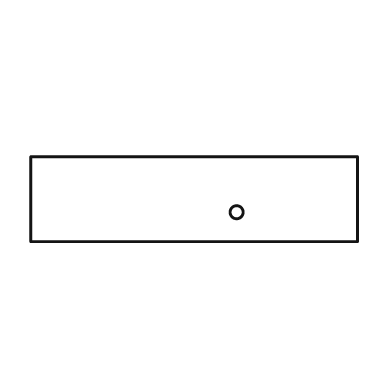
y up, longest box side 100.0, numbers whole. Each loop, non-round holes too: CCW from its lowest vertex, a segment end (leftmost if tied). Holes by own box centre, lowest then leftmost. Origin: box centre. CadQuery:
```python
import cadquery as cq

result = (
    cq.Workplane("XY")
    .moveTo(-50.0, -13.0)
    .lineTo(50.0, -13.0)
    .lineTo(50.0, 13.0)
    .lineTo(-50.0, 13.0)
    .close()
    .moveTo(13.0, -4.0)
    .circle(2.0)
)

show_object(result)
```